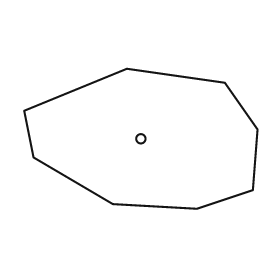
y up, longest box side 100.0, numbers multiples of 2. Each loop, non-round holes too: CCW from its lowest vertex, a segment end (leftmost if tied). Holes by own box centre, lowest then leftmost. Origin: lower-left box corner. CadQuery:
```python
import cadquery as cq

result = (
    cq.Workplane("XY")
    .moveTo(74.0, 0.0)
    .lineTo(98.0, 8.0)
    .lineTo(100.0, 34.0)
    .lineTo(86.0, 54.0)
    .lineTo(44.0, 60.0)
    .lineTo(0.0, 42.0)
    .lineTo(4.0, 22.0)
    .lineTo(38.0, 2.0)
    .close()
    .moveTo(50.0, 30.0)
    .circle(2.0)
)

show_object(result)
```